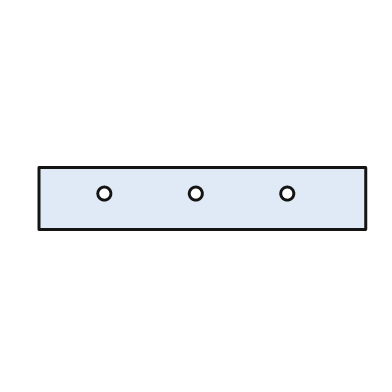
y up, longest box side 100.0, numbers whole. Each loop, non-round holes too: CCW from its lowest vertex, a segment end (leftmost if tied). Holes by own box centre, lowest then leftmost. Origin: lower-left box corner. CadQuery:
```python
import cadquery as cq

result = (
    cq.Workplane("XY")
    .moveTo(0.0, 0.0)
    .lineTo(100.0, 0.0)
    .lineTo(100.0, 19.0)
    .lineTo(0.0, 19.0)
    .close()
    .moveTo(20.0, 11.0)
    .circle(2.0)
    .moveTo(48.0, 11.0)
    .circle(2.0)
    .moveTo(76.0, 11.0)
    .circle(2.0)
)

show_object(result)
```